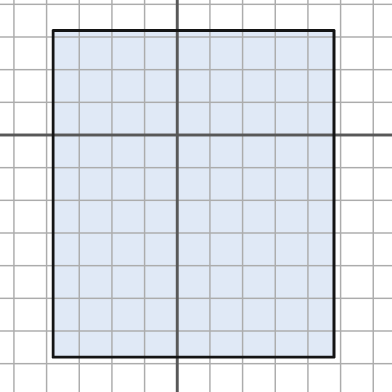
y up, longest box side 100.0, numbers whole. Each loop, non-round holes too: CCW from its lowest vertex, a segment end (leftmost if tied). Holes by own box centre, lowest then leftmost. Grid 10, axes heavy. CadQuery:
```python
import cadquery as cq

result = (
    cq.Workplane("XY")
    .moveTo(-38.0, -68.0)
    .lineTo(48.0, -68.0)
    .lineTo(48.0, 32.0)
    .lineTo(-38.0, 32.0)
    .close()
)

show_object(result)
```